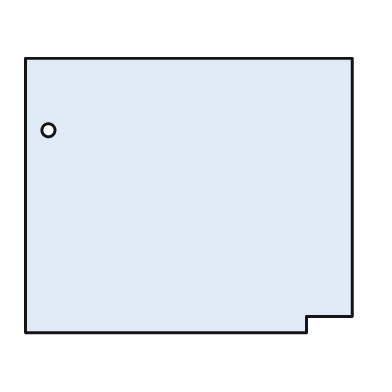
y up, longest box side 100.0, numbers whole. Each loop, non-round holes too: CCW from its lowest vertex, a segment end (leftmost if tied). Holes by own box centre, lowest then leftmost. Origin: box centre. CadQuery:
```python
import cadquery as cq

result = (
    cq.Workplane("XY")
    .moveTo(-50.0, -42.0)
    .lineTo(36.0, -42.0)
    .lineTo(36.0, -37.0)
    .lineTo(50.0, -37.0)
    .lineTo(50.0, 42.0)
    .lineTo(-50.0, 42.0)
    .close()
    .moveTo(-43.0, 20.0)
    .circle(2.0)
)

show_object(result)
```